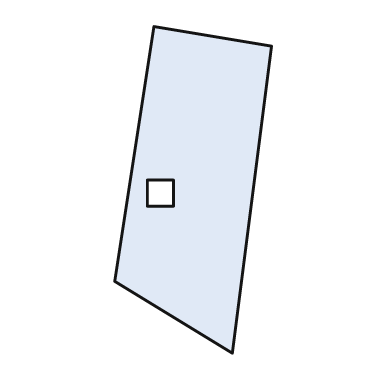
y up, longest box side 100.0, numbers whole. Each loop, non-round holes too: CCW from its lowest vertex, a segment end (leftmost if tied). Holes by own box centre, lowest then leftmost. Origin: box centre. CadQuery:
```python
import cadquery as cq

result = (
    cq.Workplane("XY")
    .moveTo(12.0, -50.0)
    .lineTo(24.0, 44.0)
    .lineTo(-12.0, 50.0)
    .lineTo(-24.0, -28.0)
    .close()
    .moveTo(-14.0, -5.0)
    .lineTo(-6.0, -5.0)
    .lineTo(-6.0, 3.0)
    .lineTo(-14.0, 3.0)
    .close()
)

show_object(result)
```